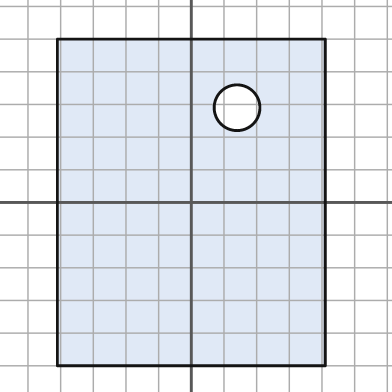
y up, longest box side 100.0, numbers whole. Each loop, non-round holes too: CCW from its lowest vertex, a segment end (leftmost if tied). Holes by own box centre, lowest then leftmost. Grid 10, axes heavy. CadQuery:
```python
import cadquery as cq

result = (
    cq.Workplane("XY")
    .moveTo(-41.0, -50.0)
    .lineTo(41.0, -50.0)
    .lineTo(41.0, 50.0)
    .lineTo(-41.0, 50.0)
    .close()
    .moveTo(14.0, 29.0)
    .circle(7.0)
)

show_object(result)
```